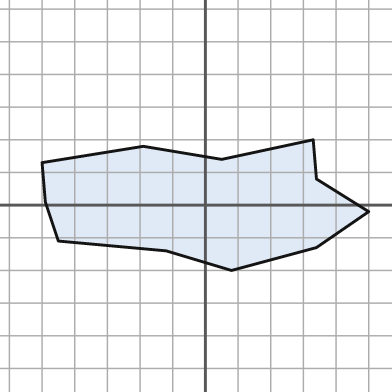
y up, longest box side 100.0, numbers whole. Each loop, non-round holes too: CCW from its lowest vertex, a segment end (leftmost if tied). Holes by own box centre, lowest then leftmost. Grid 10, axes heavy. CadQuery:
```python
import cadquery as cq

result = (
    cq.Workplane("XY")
    .moveTo(8.0, -20.0)
    .lineTo(34.0, -13.0)
    .lineTo(50.0, -2.0)
    .lineTo(34.0, 8.0)
    .lineTo(33.0, 20.0)
    .lineTo(5.0, 14.0)
    .lineTo(-19.0, 18.0)
    .lineTo(-50.0, 13.0)
    .lineTo(-49.0, 1.0)
    .lineTo(-45.0, -11.0)
    .lineTo(-12.0, -14.0)
    .close()
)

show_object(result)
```